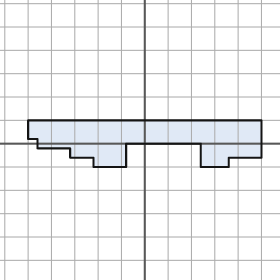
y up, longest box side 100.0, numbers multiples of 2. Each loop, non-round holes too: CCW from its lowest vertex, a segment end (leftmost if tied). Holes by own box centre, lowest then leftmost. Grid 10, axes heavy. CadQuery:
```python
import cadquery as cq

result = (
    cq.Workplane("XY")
    .moveTo(-22.0, -10.0)
    .lineTo(-8.0, -10.0)
    .lineTo(-8.0, 0.0)
    .lineTo(24.0, 0.0)
    .lineTo(24.0, -10.0)
    .lineTo(36.0, -10.0)
    .lineTo(36.0, -6.0)
    .lineTo(50.0, -6.0)
    .lineTo(50.0, 10.0)
    .lineTo(-50.0, 10.0)
    .lineTo(-50.0, 2.0)
    .lineTo(-46.0, 2.0)
    .lineTo(-46.0, -2.0)
    .lineTo(-32.0, -2.0)
    .lineTo(-32.0, -6.0)
    .lineTo(-22.0, -6.0)
    .close()
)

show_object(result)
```